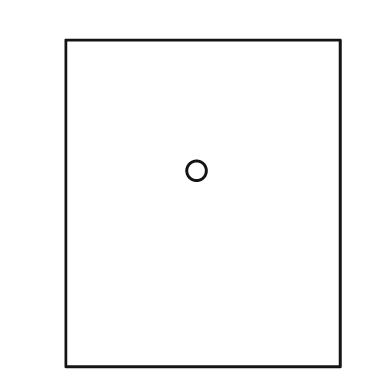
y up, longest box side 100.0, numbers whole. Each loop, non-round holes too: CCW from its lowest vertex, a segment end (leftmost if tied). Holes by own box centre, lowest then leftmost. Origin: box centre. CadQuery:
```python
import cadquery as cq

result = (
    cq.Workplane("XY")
    .moveTo(-42.0, -50.0)
    .lineTo(42.0, -50.0)
    .lineTo(42.0, 50.0)
    .lineTo(-42.0, 50.0)
    .close()
    .moveTo(-2.0, 10.0)
    .circle(3.0)
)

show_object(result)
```